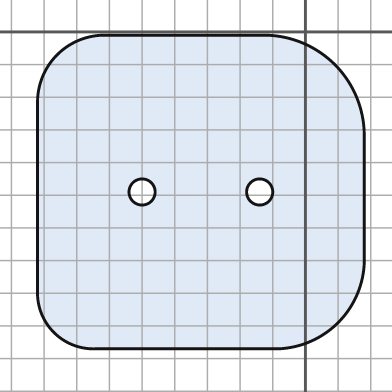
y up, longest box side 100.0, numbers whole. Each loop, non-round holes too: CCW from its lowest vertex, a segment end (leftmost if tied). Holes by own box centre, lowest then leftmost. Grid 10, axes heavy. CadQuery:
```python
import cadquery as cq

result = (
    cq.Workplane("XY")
    .moveTo(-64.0, -97.0)
    .lineTo(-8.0, -97.0)
    .threePointArc((10.0, -89.0), (18.0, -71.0))
    .lineTo(18.0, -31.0)
    .threePointArc((9.0, -10.0), (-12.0, -1.0))
    .lineTo(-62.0, -1.0)
    .threePointArc((-76.0, -7.0), (-82.0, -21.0))
    .lineTo(-82.0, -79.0)
    .threePointArc((-77.0, -92.0), (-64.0, -97.0))
    .close()
    .moveTo(-50.0, -49.0)
    .circle(4.0)
    .moveTo(-14.0, -49.0)
    .circle(4.0)
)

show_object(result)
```